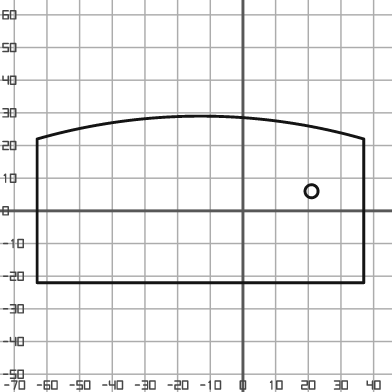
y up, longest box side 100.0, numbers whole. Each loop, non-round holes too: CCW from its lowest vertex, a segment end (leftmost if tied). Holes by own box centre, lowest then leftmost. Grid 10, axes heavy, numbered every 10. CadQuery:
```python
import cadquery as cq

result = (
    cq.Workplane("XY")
    .moveTo(-63.0, -22.0)
    .lineTo(37.0, -22.0)
    .lineTo(37.0, 22.0)
    .threePointArc((-13.0, 29.0), (-63.0, 22.0))
    .close()
    .moveTo(21.0, 6.0)
    .circle(2.0)
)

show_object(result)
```